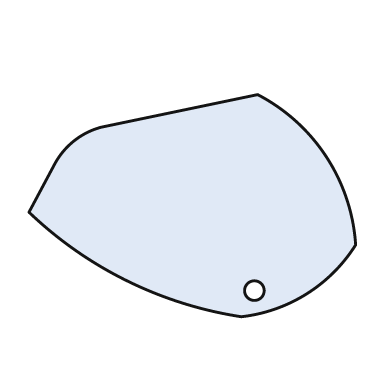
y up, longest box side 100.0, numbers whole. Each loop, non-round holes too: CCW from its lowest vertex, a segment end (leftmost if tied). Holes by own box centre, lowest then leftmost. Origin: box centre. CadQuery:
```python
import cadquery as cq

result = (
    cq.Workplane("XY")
    .moveTo(15.0, -34.0)
    .threePointArc((35.0, -27.0), (50.0, -12.0))
    .threePointArc((41.0, 15.0), (20.0, 34.0))
    .lineTo(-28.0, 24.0)
    .threePointArc((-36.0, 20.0), (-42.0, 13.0))
    .lineTo(-50.0, -2.0)
    .threePointArc((-20.0, -23.0), (15.0, -34.0))
    .close()
    .moveTo(19.0, -26.0)
    .circle(3.0)
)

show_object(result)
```